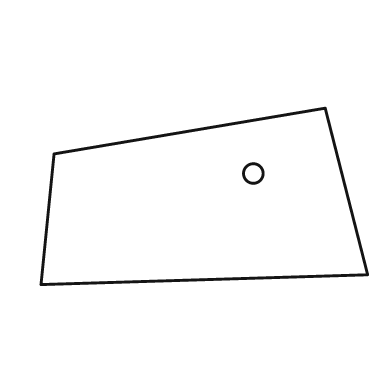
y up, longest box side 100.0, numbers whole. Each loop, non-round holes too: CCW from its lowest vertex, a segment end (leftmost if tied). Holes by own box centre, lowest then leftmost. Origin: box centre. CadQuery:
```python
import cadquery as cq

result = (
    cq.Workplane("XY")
    .moveTo(-50.0, -27.0)
    .lineTo(50.0, -24.0)
    .lineTo(37.0, 27.0)
    .lineTo(-46.0, 13.0)
    .close()
    .moveTo(15.0, 7.0)
    .circle(3.0)
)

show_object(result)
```